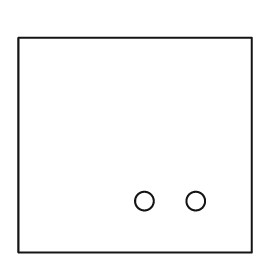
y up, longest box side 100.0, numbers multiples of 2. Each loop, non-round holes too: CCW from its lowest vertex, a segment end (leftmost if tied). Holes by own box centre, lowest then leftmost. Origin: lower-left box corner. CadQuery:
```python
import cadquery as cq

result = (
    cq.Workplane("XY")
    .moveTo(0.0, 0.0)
    .lineTo(100.0, 0.0)
    .lineTo(100.0, 92.0)
    .lineTo(0.0, 92.0)
    .close()
    .moveTo(54.0, 22.0)
    .circle(4.0)
    .moveTo(76.0, 22.0)
    .circle(4.0)
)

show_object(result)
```